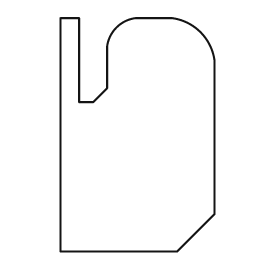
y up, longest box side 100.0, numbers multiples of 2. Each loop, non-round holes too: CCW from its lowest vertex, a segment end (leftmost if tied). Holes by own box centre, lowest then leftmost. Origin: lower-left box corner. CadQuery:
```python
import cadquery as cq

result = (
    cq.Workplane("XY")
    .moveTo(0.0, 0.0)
    .lineTo(50.0, 0.0)
    .lineTo(66.0, 16.0)
    .lineTo(66.0, 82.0)
    .threePointArc((60.0, 94.0), (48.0, 100.0))
    .lineTo(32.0, 100.0)
    .threePointArc((24.0, 96.0), (20.0, 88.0))
    .lineTo(20.0, 70.0)
    .lineTo(14.0, 64.0)
    .lineTo(8.0, 64.0)
    .lineTo(8.0, 100.0)
    .lineTo(0.0, 100.0)
    .close()
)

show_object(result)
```